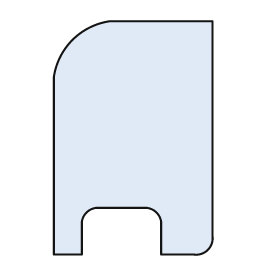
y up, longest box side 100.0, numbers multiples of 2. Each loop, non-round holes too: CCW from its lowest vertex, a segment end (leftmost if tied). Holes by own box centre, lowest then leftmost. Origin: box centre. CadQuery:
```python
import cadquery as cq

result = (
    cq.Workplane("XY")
    .moveTo(-34.0, -50.0)
    .lineTo(-22.0, -50.0)
    .lineTo(-22.0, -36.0)
    .threePointArc((-20.0, -32.0), (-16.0, -30.0))
    .lineTo(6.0, -30.0)
    .threePointArc((10.0, -32.0), (12.0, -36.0))
    .lineTo(12.0, -50.0)
    .lineTo(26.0, -50.0)
    .threePointArc((32.0, -48.0), (34.0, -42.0))
    .lineTo(34.0, 50.0)
    .lineTo(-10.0, 50.0)
    .threePointArc((-26.0, 42.0), (-34.0, 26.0))
    .close()
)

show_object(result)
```